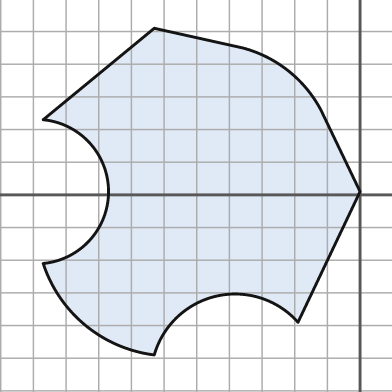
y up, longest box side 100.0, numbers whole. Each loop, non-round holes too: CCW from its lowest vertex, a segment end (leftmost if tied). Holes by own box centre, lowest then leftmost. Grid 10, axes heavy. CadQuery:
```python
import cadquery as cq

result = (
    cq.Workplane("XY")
    .moveTo(-63.0, -49.0)
    .threePointArc((-44.0, -31.0), (-19.0, -39.0))
    .lineTo(0.0, 1.0)
    .lineTo(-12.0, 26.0)
    .threePointArc((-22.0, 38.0), (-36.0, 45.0))
    .lineTo(-63.0, 51.0)
    .lineTo(-97.0, 23.0)
    .threePointArc((-77.0, 1.0), (-97.0, -21.0))
    .threePointArc((-84.0, -40.0), (-63.0, -49.0))
    .close()
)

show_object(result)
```